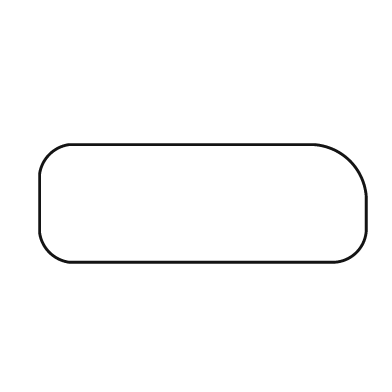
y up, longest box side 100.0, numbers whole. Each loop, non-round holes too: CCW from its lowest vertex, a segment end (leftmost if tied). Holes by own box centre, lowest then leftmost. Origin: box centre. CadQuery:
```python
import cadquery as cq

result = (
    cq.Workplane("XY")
    .moveTo(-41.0, -18.0)
    .lineTo(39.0, -18.0)
    .threePointArc((47.0, -15.0), (50.0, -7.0))
    .lineTo(50.0, 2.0)
    .threePointArc((45.0, 13.0), (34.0, 18.0))
    .lineTo(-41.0, 18.0)
    .threePointArc((-47.0, 15.0), (-50.0, 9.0))
    .lineTo(-50.0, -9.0)
    .threePointArc((-47.0, -15.0), (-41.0, -18.0))
    .close()
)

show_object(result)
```